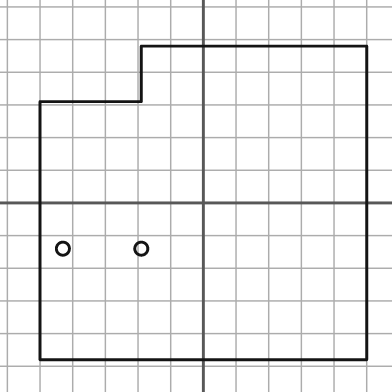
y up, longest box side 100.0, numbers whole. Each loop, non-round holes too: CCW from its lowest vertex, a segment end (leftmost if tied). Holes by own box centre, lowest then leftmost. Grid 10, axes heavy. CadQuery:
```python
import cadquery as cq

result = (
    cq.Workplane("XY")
    .moveTo(-50.0, -48.0)
    .lineTo(50.0, -48.0)
    .lineTo(50.0, 48.0)
    .lineTo(-19.0, 48.0)
    .lineTo(-19.0, 31.0)
    .lineTo(-50.0, 31.0)
    .close()
    .moveTo(-43.0, -14.0)
    .circle(2.0)
    .moveTo(-19.0, -14.0)
    .circle(2.0)
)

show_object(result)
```